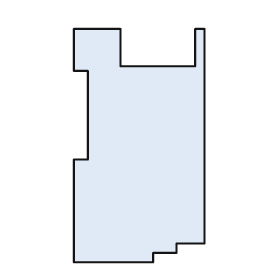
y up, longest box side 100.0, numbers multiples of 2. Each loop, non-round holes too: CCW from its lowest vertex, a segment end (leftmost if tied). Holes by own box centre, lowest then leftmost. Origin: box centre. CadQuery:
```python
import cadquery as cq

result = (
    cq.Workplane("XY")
    .moveTo(-28.0, -50.0)
    .lineTo(6.0, -50.0)
    .lineTo(6.0, -46.0)
    .lineTo(16.0, -46.0)
    .lineTo(16.0, -42.0)
    .lineTo(28.0, -42.0)
    .lineTo(28.0, 50.0)
    .lineTo(24.0, 50.0)
    .lineTo(24.0, 34.0)
    .lineTo(-8.0, 34.0)
    .lineTo(-8.0, 50.0)
    .lineTo(-28.0, 50.0)
    .lineTo(-28.0, 32.0)
    .lineTo(-22.0, 32.0)
    .lineTo(-22.0, -6.0)
    .lineTo(-28.0, -6.0)
    .close()
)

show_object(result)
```